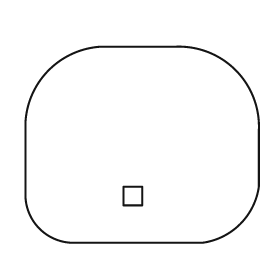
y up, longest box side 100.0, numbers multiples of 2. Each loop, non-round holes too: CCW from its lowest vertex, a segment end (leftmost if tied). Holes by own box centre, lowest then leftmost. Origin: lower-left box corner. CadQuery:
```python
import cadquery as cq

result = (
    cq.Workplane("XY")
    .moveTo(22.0, 0.0)
    .lineTo(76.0, 0.0)
    .threePointArc((92.0, 8.0), (100.0, 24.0))
    .lineTo(100.0, 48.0)
    .threePointArc((90.0, 74.0), (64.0, 84.0))
    .lineTo(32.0, 84.0)
    .threePointArc((10.0, 74.0), (0.0, 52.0))
    .lineTo(0.0, 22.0)
    .threePointArc((6.0, 6.0), (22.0, 0.0))
    .close()
    .moveTo(42.0, 16.0)
    .lineTo(50.0, 16.0)
    .lineTo(50.0, 24.0)
    .lineTo(42.0, 24.0)
    .close()
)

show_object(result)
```